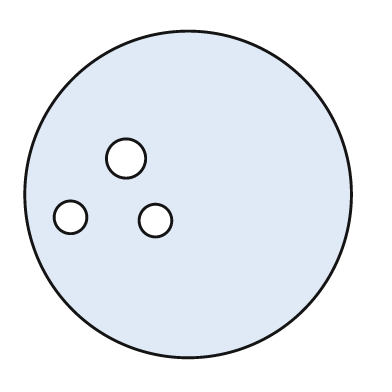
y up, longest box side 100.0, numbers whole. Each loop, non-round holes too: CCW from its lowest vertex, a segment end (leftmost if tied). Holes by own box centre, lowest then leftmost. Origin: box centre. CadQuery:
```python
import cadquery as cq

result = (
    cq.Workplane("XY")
    .moveTo(0.0, 0.0)
    .circle(50.0)
    .moveTo(-10.0, -8.0)
    .circle(5.0)
    .moveTo(-36.0, -7.0)
    .circle(5.0)
    .moveTo(-19.0, 11.0)
    .circle(6.0)
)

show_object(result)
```